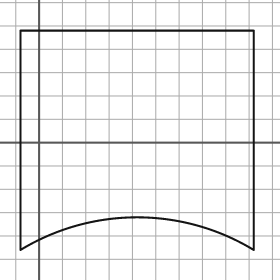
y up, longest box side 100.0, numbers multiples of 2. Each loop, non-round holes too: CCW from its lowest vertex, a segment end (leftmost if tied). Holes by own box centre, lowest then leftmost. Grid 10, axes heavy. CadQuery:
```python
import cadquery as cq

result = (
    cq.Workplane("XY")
    .moveTo(-8.0, -46.0)
    .threePointArc((42.0, -32.0), (92.0, -46.0))
    .lineTo(92.0, 48.0)
    .lineTo(-8.0, 48.0)
    .close()
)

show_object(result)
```